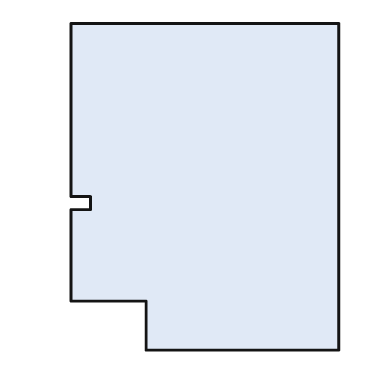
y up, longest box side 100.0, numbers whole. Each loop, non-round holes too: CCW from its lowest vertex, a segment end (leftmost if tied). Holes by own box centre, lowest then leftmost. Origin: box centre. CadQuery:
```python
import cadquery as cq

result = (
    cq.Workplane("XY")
    .moveTo(-18.0, -50.0)
    .lineTo(41.0, -50.0)
    .lineTo(41.0, 50.0)
    .lineTo(-41.0, 50.0)
    .lineTo(-41.0, -3.0)
    .lineTo(-35.0, -3.0)
    .lineTo(-35.0, -7.0)
    .lineTo(-41.0, -7.0)
    .lineTo(-41.0, -35.0)
    .lineTo(-18.0, -35.0)
    .close()
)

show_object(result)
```